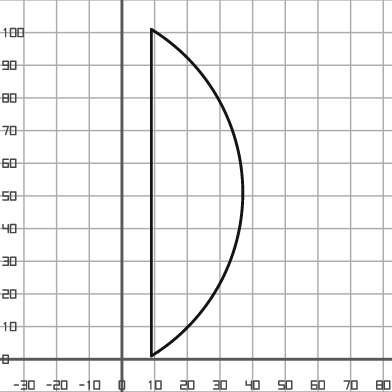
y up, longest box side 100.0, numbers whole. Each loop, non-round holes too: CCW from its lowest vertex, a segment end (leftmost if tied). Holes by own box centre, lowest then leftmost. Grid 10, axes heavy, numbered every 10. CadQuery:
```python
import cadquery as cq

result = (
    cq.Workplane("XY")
    .moveTo(9.0, 1.0)
    .threePointArc((37.0, 51.0), (9.0, 101.0))
    .close()
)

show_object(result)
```